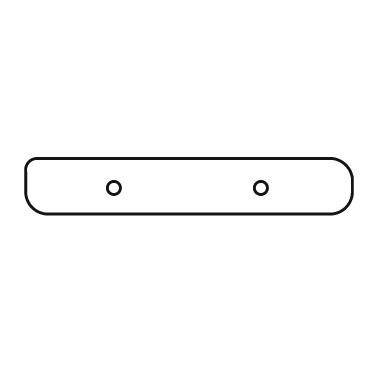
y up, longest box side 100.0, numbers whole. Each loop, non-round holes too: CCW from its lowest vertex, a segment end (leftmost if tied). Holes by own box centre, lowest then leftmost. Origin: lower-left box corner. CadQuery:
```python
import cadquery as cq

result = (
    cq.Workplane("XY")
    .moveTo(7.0, 0.0)
    .lineTo(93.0, 0.0)
    .threePointArc((98.0, 2.0), (100.0, 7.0))
    .lineTo(100.0, 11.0)
    .threePointArc((98.0, 15.0), (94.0, 17.0))
    .lineTo(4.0, 17.0)
    .threePointArc((1.0, 16.0), (0.0, 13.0))
    .lineTo(0.0, 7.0)
    .threePointArc((2.0, 2.0), (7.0, 0.0))
    .close()
    .moveTo(27.0, 8.0)
    .circle(2.0)
    .moveTo(72.0, 8.0)
    .circle(2.0)
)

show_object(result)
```